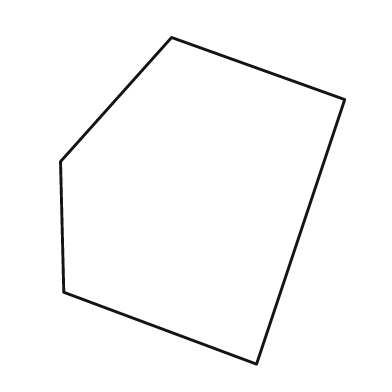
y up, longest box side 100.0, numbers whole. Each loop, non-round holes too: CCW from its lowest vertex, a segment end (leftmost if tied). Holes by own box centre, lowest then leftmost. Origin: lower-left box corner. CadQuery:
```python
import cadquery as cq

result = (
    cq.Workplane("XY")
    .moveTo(60.0, 0.0)
    .lineTo(87.0, 81.0)
    .lineTo(34.0, 100.0)
    .lineTo(0.0, 62.0)
    .lineTo(1.0, 22.0)
    .close()
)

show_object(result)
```